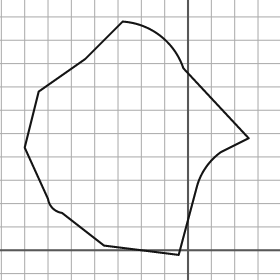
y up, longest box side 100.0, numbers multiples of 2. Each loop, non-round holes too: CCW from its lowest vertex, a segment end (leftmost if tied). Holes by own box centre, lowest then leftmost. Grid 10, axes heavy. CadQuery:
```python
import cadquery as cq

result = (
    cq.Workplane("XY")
    .moveTo(-4.0, -2.0)
    .lineTo(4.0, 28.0)
    .threePointArc((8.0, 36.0), (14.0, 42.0))
    .lineTo(26.0, 48.0)
    .lineTo(-2.0, 78.0)
    .threePointArc((-12.0, 92.0), (-28.0, 98.0))
    .lineTo(-44.0, 82.0)
    .lineTo(-64.0, 68.0)
    .lineTo(-70.0, 44.0)
    .lineTo(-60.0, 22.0)
    .threePointArc((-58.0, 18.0), (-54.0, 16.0))
    .lineTo(-36.0, 2.0)
    .close()
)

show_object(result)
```